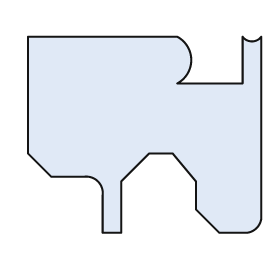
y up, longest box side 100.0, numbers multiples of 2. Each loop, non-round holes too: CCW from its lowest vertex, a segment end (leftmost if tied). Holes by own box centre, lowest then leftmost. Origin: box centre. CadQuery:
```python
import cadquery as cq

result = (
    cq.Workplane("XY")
    .moveTo(-18.0, -42.0)
    .lineTo(-10.0, -42.0)
    .lineTo(-10.0, -20.0)
    .lineTo(2.0, -8.0)
    .lineTo(12.0, -8.0)
    .lineTo(22.0, -20.0)
    .lineTo(22.0, -32.0)
    .lineTo(32.0, -42.0)
    .lineTo(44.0, -42.0)
    .threePointArc((48.0, -40.0), (50.0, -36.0))
    .lineTo(50.0, 42.0)
    .threePointArc((46.0, 40.0), (42.0, 42.0))
    .lineTo(42.0, 22.0)
    .lineTo(14.0, 22.0)
    .threePointArc((20.0, 32.0), (14.0, 42.0))
    .lineTo(-50.0, 42.0)
    .lineTo(-50.0, -8.0)
    .lineTo(-40.0, -18.0)
    .lineTo(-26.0, -18.0)
    .threePointArc((-20.0, -20.0), (-18.0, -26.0))
    .close()
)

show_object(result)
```